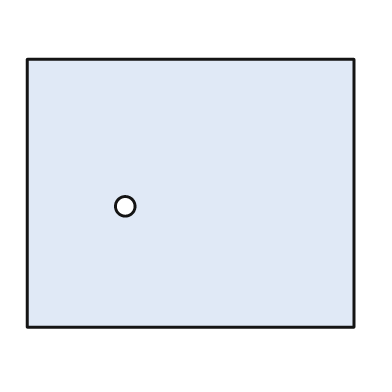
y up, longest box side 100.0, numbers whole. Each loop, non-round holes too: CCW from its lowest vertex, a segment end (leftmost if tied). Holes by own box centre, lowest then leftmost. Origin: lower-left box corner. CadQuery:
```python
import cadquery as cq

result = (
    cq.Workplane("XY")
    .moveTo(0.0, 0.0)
    .lineTo(100.0, 0.0)
    .lineTo(100.0, 82.0)
    .lineTo(0.0, 82.0)
    .close()
    .moveTo(30.0, 37.0)
    .circle(3.0)
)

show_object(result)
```